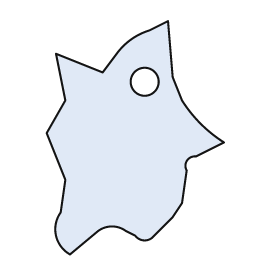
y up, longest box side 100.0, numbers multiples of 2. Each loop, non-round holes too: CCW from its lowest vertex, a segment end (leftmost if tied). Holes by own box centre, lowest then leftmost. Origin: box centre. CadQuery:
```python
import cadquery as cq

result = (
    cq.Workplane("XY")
    .moveTo(-28.0, -50.0)
    .lineTo(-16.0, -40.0)
    .threePointArc((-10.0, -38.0), (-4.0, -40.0))
    .lineTo(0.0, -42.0)
    .threePointArc((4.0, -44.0), (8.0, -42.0))
    .lineTo(16.0, -34.0)
    .lineTo(20.0, -28.0)
    .lineTo(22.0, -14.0)
    .threePointArc((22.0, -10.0), (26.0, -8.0))
    .lineTo(38.0, -2.0)
    .threePointArc((28.0, 6.0), (20.0, 16.0))
    .lineTo(16.0, 26.0)
    .lineTo(14.0, 50.0)
    .lineTo(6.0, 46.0)
    .threePointArc((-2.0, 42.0), (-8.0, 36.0))
    .lineTo(-14.0, 28.0)
    .lineTo(-34.0, 36.0)
    .lineTo(-30.0, 16.0)
    .lineTo(-38.0, 2.0)
    .lineTo(-30.0, -18.0)
    .lineTo(-32.0, -32.0)
    .threePointArc((-34.0, -42.0), (-28.0, -50.0))
    .close()
    .moveTo(4.0, 24.0)
    .circle(6.0)
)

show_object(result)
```